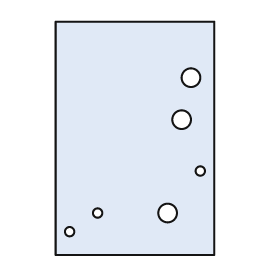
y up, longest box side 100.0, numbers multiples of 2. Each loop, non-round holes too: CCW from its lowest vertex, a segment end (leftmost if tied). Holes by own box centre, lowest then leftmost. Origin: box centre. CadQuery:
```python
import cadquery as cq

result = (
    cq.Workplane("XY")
    .moveTo(-34.0, -50.0)
    .lineTo(34.0, -50.0)
    .lineTo(34.0, 50.0)
    .lineTo(-34.0, 50.0)
    .close()
    .moveTo(-28.0, -40.0)
    .circle(2.0)
    .moveTo(-16.0, -32.0)
    .circle(2.0)
    .moveTo(14.0, -32.0)
    .circle(4.0)
    .moveTo(28.0, -14.0)
    .circle(2.0)
    .moveTo(20.0, 8.0)
    .circle(4.0)
    .moveTo(24.0, 26.0)
    .circle(4.0)
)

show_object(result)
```